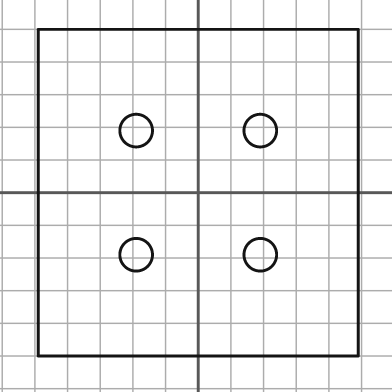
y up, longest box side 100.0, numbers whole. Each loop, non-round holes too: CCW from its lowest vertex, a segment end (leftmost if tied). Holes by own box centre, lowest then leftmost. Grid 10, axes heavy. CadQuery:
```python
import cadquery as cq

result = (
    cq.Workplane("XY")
    .moveTo(-49.0, -50.0)
    .lineTo(49.0, -50.0)
    .lineTo(49.0, 50.0)
    .lineTo(-49.0, 50.0)
    .close()
    .moveTo(-19.0, -19.0)
    .circle(5.0)
    .moveTo(19.0, -19.0)
    .circle(5.0)
    .moveTo(-19.0, 19.0)
    .circle(5.0)
    .moveTo(19.0, 19.0)
    .circle(5.0)
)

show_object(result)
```